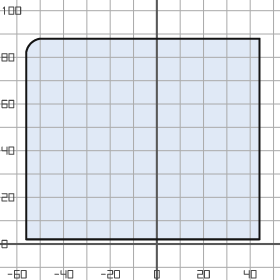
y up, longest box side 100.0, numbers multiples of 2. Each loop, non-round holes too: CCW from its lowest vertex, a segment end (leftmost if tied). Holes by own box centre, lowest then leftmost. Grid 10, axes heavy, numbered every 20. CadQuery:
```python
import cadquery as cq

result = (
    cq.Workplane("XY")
    .moveTo(-56.0, 2.0)
    .lineTo(44.0, 2.0)
    .lineTo(44.0, 88.0)
    .lineTo(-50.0, 88.0)
    .threePointArc((-54.0, 86.0), (-56.0, 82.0))
    .close()
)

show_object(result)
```